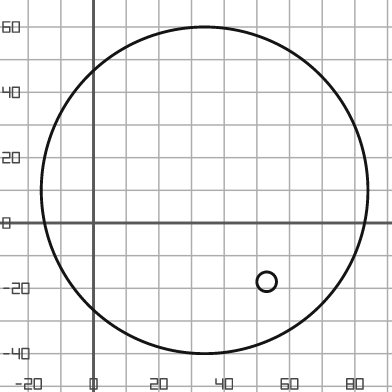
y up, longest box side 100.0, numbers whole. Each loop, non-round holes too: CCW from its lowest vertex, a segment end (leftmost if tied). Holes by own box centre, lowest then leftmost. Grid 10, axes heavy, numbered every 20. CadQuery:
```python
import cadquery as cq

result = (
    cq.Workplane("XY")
    .moveTo(34.0, 10.0)
    .circle(50.0)
    .moveTo(53.0, -18.0)
    .circle(3.0)
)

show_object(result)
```